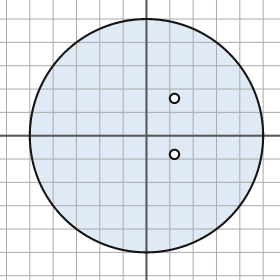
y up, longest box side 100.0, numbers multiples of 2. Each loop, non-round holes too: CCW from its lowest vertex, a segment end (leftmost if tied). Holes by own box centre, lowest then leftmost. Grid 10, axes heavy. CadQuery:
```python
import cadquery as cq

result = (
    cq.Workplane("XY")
    .moveTo(0.0, 0.0)
    .circle(50.0)
    .moveTo(12.0, -8.0)
    .circle(2.0)
    .moveTo(12.0, 16.0)
    .circle(2.0)
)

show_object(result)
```